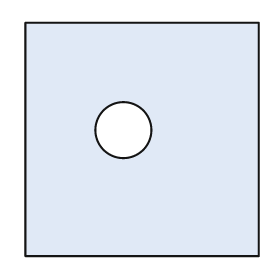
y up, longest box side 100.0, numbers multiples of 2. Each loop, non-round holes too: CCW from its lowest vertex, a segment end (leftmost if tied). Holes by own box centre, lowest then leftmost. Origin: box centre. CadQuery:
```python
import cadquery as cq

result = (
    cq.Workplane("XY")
    .moveTo(-50.0, -50.0)
    .lineTo(50.0, -50.0)
    .lineTo(50.0, 50.0)
    .lineTo(-50.0, 50.0)
    .close()
    .moveTo(-8.0, 4.0)
    .circle(12.0)
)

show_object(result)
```